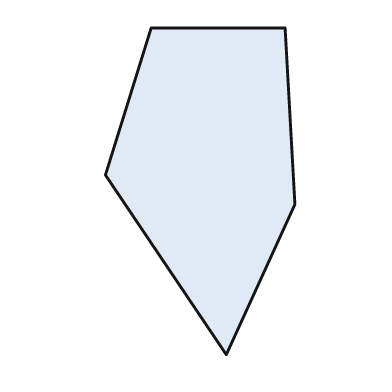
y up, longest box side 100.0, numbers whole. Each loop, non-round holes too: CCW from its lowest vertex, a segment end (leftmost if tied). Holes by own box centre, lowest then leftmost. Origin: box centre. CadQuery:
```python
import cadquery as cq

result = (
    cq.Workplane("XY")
    .moveTo(8.0, -50.0)
    .lineTo(29.0, -4.0)
    .lineTo(26.0, 50.0)
    .lineTo(-15.0, 50.0)
    .lineTo(-29.0, 5.0)
    .close()
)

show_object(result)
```